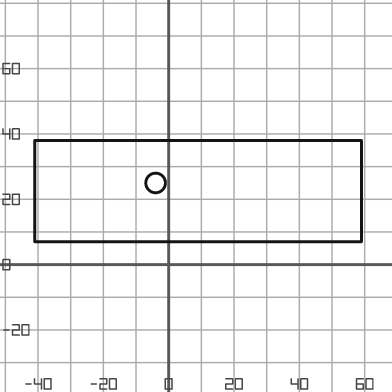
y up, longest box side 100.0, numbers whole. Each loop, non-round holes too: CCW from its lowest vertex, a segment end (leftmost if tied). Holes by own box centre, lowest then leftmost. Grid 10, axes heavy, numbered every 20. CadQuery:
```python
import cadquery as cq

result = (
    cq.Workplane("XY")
    .moveTo(-41.0, 7.0)
    .lineTo(59.0, 7.0)
    .lineTo(59.0, 38.0)
    .lineTo(-41.0, 38.0)
    .close()
    .moveTo(-4.0, 25.0)
    .circle(3.0)
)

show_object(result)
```